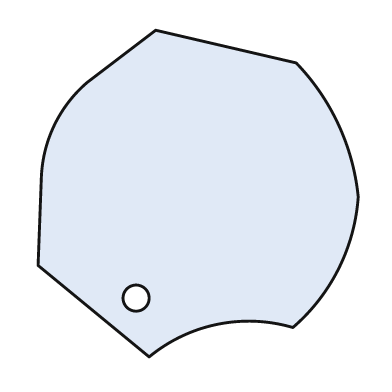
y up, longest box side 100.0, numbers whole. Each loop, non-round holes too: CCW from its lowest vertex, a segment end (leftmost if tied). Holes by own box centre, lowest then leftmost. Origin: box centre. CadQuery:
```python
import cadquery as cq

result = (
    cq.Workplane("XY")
    .moveTo(-15.0, -50.0)
    .threePointArc((6.0, -40.0), (29.0, -41.0))
    .threePointArc((43.0, -23.0), (49.0, -1.0))
    .threePointArc((43.0, 21.0), (30.0, 40.0))
    .lineTo(-13.0, 50.0)
    .lineTo(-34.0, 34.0)
    .threePointArc((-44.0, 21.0), (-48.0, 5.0))
    .lineTo(-49.0, -22.0)
    .close()
    .moveTo(-19.0, -32.0)
    .circle(4.0)
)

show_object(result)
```